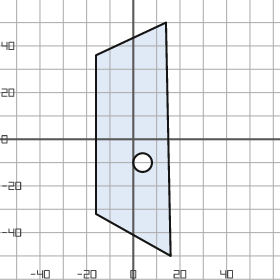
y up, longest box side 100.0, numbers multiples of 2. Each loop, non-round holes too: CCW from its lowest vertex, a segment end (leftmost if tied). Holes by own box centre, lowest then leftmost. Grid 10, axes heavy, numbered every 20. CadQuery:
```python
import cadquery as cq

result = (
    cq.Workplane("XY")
    .moveTo(16.0, -50.0)
    .lineTo(14.0, 50.0)
    .lineTo(-16.0, 36.0)
    .lineTo(-16.0, -32.0)
    .close()
    .moveTo(4.0, -10.0)
    .circle(4.0)
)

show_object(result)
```